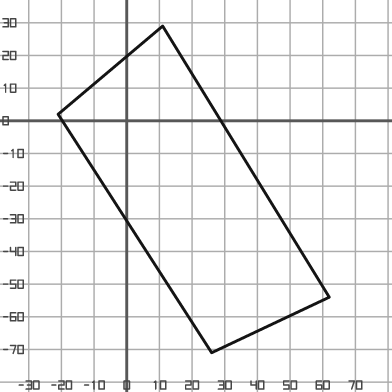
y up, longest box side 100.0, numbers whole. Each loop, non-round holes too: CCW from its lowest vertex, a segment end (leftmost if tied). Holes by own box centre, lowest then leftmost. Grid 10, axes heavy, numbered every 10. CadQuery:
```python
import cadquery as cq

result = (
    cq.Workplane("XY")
    .moveTo(26.0, -71.0)
    .lineTo(62.0, -54.0)
    .lineTo(11.0, 29.0)
    .lineTo(-21.0, 2.0)
    .close()
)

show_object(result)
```